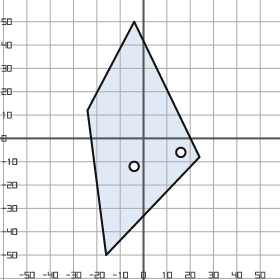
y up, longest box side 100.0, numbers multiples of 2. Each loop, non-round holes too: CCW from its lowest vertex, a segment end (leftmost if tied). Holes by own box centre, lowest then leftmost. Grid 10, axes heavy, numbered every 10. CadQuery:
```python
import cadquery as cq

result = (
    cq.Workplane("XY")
    .moveTo(-16.0, -50.0)
    .lineTo(24.0, -8.0)
    .lineTo(-4.0, 50.0)
    .lineTo(-24.0, 12.0)
    .close()
    .moveTo(-4.0, -12.0)
    .circle(2.0)
    .moveTo(16.0, -6.0)
    .circle(2.0)
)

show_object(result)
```